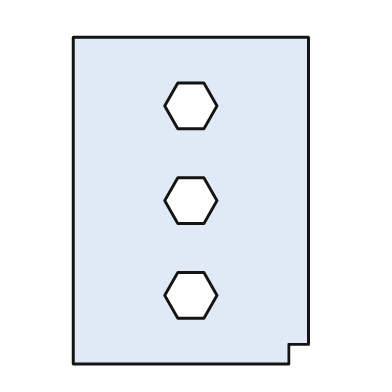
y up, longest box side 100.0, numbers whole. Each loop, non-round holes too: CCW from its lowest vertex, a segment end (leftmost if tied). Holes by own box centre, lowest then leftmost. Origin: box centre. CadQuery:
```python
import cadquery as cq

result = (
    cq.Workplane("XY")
    .moveTo(-36.0, -50.0)
    .lineTo(30.0, -50.0)
    .lineTo(30.0, -44.0)
    .lineTo(36.0, -44.0)
    .lineTo(36.0, 50.0)
    .lineTo(-36.0, 50.0)
    .close()
    .moveTo(-4.0, -36.0)
    .lineTo(4.0, -36.0)
    .lineTo(8.0, -29.0)
    .lineTo(4.0, -22.0)
    .lineTo(-4.0, -22.0)
    .lineTo(-8.0, -29.0)
    .close()
    .moveTo(-4.0, -7.0)
    .lineTo(4.0, -7.0)
    .lineTo(8.0, 0.0)
    .lineTo(4.0, 7.0)
    .lineTo(-4.0, 7.0)
    .lineTo(-8.0, 0.0)
    .close()
    .moveTo(-4.0, 22.0)
    .lineTo(4.0, 22.0)
    .lineTo(8.0, 29.0)
    .lineTo(4.0, 36.0)
    .lineTo(-4.0, 36.0)
    .lineTo(-8.0, 29.0)
    .close()
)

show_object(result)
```